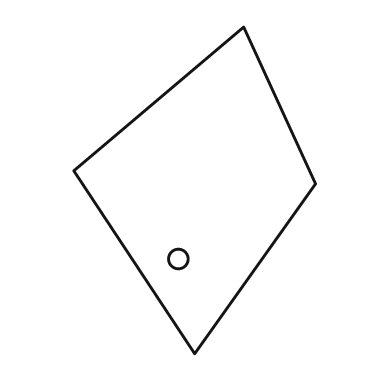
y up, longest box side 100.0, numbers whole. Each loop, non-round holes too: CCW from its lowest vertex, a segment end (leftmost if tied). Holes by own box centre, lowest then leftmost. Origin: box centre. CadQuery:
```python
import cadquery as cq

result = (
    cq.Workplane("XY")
    .moveTo(0.0, -50.0)
    .lineTo(37.0, 2.0)
    .lineTo(15.0, 50.0)
    .lineTo(-37.0, 6.0)
    .close()
    .moveTo(-5.0, -21.0)
    .circle(3.0)
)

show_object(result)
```